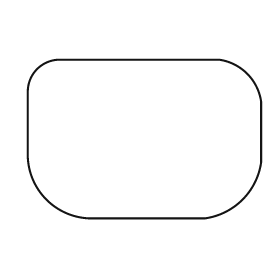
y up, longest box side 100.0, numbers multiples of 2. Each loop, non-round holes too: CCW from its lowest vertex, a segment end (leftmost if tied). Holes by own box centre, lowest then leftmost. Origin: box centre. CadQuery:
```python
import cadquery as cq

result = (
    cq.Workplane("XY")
    .moveTo(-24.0, -34.0)
    .lineTo(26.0, -34.0)
    .threePointArc((42.0, -26.0), (50.0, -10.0))
    .lineTo(50.0, 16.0)
    .threePointArc((44.0, 28.0), (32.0, 34.0))
    .lineTo(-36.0, 34.0)
    .threePointArc((-46.0, 30.0), (-50.0, 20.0))
    .lineTo(-50.0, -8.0)
    .threePointArc((-42.0, -26.0), (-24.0, -34.0))
    .close()
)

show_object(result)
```